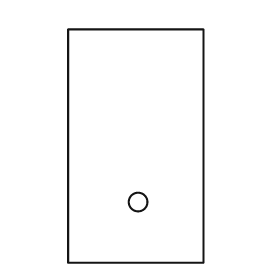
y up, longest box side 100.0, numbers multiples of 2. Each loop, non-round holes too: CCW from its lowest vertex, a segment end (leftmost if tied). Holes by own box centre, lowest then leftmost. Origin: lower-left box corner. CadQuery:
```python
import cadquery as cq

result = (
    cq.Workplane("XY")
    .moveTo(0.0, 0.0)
    .lineTo(58.0, 0.0)
    .lineTo(58.0, 100.0)
    .lineTo(0.0, 100.0)
    .close()
    .moveTo(30.0, 26.0)
    .circle(4.0)
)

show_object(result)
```